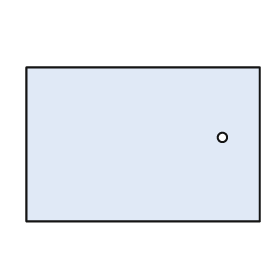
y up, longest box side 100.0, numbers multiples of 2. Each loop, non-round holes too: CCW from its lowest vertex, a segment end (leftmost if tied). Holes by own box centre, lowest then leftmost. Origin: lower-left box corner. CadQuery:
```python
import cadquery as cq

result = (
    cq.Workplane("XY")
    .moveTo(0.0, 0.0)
    .lineTo(100.0, 0.0)
    .lineTo(100.0, 66.0)
    .lineTo(0.0, 66.0)
    .close()
    .moveTo(84.0, 36.0)
    .circle(2.0)
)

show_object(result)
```